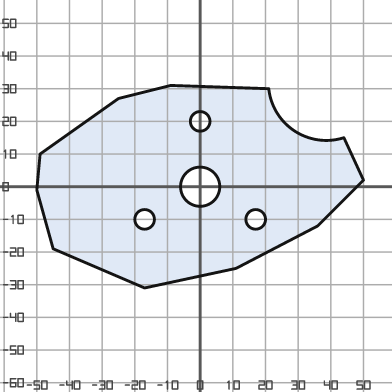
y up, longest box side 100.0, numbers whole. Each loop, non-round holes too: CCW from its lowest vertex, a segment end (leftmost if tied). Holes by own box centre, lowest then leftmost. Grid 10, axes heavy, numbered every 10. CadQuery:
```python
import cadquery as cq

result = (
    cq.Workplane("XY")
    .moveTo(-17.0, -31.0)
    .lineTo(11.0, -25.0)
    .lineTo(36.0, -12.0)
    .lineTo(50.0, 2.0)
    .lineTo(44.0, 15.0)
    .threePointArc((29.0, 17.0), (21.0, 30.0))
    .lineTo(-9.0, 31.0)
    .lineTo(-25.0, 27.0)
    .lineTo(-49.0, 10.0)
    .lineTo(-50.0, -1.0)
    .lineTo(-45.0, -19.0)
    .close()
    .moveTo(-17.0, -10.0)
    .circle(3.0)
    .moveTo(17.0, -10.0)
    .circle(3.0)
    .moveTo(0.0, 0.0)
    .circle(6.0)
    .moveTo(0.0, 20.0)
    .circle(3.0)
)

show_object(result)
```